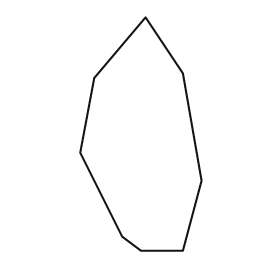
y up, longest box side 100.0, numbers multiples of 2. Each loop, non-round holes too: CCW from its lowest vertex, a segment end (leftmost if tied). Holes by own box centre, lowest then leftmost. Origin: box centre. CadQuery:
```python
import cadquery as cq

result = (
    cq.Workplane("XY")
    .moveTo(0.0, -50.0)
    .lineTo(18.0, -50.0)
    .lineTo(26.0, -20.0)
    .lineTo(18.0, 26.0)
    .lineTo(2.0, 50.0)
    .lineTo(-20.0, 24.0)
    .lineTo(-26.0, -8.0)
    .lineTo(-8.0, -44.0)
    .close()
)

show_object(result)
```